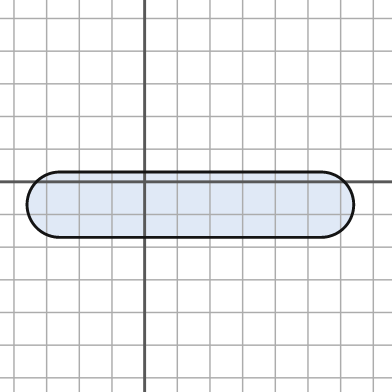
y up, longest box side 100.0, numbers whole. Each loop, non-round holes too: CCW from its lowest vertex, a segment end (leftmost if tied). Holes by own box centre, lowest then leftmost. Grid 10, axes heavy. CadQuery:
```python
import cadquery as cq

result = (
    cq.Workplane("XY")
    .moveTo(-26.0, -17.0)
    .lineTo(54.0, -17.0)
    .threePointArc((64.0, -7.0), (54.0, 3.0))
    .lineTo(-26.0, 3.0)
    .threePointArc((-36.0, -7.0), (-26.0, -17.0))
    .close()
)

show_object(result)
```